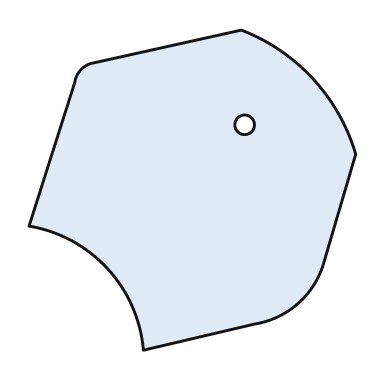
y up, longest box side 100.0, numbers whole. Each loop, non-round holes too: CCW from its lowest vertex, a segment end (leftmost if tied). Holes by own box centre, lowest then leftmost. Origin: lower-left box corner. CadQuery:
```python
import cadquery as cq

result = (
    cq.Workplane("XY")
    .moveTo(35.0, 0.0)
    .lineTo(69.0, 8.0)
    .threePointArc((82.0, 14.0), (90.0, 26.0))
    .lineTo(100.0, 60.0)
    .threePointArc((87.0, 83.0), (65.0, 98.0))
    .lineTo(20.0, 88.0)
    .threePointArc((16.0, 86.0), (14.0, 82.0))
    .lineTo(0.0, 38.0)
    .threePointArc((24.0, 25.0), (35.0, 0.0))
    .close()
    .moveTo(66.0, 69.0)
    .circle(3.0)
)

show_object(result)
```